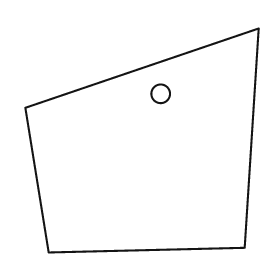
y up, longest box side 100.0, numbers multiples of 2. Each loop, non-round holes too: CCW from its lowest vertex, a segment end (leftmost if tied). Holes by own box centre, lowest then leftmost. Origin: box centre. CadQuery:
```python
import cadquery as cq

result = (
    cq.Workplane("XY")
    .moveTo(-40.0, -48.0)
    .lineTo(44.0, -46.0)
    .lineTo(50.0, 48.0)
    .lineTo(-50.0, 14.0)
    .close()
    .moveTo(8.0, 20.0)
    .circle(4.0)
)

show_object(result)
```